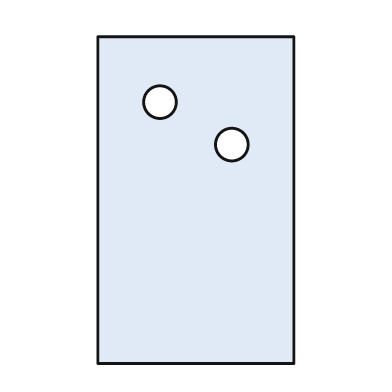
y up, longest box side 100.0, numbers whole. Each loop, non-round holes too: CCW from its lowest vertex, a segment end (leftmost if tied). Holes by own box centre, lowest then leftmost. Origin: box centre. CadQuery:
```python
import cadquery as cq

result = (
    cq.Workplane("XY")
    .moveTo(-30.0, -50.0)
    .lineTo(30.0, -50.0)
    .lineTo(30.0, 50.0)
    .lineTo(-30.0, 50.0)
    .close()
    .moveTo(11.0, 17.0)
    .circle(5.0)
    .moveTo(-11.0, 30.0)
    .circle(5.0)
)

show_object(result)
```